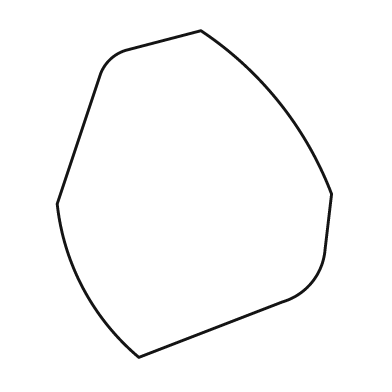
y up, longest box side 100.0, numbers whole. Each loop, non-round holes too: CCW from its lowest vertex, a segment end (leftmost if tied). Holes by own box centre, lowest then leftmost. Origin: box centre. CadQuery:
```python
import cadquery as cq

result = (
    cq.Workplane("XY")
    .moveTo(-17.0, -50.0)
    .lineTo(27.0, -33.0)
    .threePointArc((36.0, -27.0), (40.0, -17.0))
    .lineTo(42.0, 0.0)
    .threePointArc((26.0, 28.0), (2.0, 50.0))
    .lineTo(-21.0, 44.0)
    .threePointArc((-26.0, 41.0), (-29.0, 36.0))
    .lineTo(-42.0, -3.0)
    .threePointArc((-34.0, -29.0), (-17.0, -50.0))
    .close()
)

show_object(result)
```